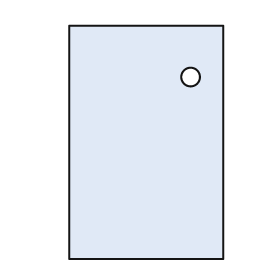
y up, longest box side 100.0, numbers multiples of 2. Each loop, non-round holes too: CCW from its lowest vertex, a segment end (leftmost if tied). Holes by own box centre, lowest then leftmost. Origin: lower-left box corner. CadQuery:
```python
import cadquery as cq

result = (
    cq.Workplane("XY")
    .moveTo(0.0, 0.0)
    .lineTo(66.0, 0.0)
    .lineTo(66.0, 100.0)
    .lineTo(0.0, 100.0)
    .close()
    .moveTo(52.0, 78.0)
    .circle(4.0)
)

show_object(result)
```